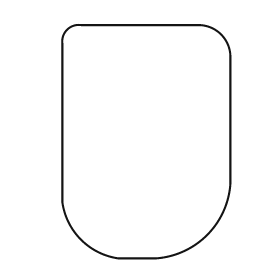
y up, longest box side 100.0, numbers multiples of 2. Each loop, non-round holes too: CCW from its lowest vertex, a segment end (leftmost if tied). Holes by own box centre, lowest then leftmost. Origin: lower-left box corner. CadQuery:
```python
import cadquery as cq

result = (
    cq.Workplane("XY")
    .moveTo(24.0, 0.0)
    .lineTo(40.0, 0.0)
    .threePointArc((62.0, 10.0), (72.0, 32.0))
    .lineTo(72.0, 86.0)
    .threePointArc((68.0, 96.0), (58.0, 100.0))
    .lineTo(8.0, 100.0)
    .threePointArc((2.0, 98.0), (0.0, 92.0))
    .lineTo(0.0, 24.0)
    .threePointArc((8.0, 8.0), (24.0, 0.0))
    .close()
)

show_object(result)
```